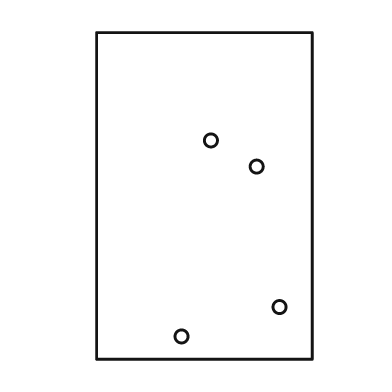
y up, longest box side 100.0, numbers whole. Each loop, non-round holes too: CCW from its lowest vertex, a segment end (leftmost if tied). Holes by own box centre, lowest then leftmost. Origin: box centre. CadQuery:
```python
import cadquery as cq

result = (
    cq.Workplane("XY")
    .moveTo(-33.0, -50.0)
    .lineTo(33.0, -50.0)
    .lineTo(33.0, 50.0)
    .lineTo(-33.0, 50.0)
    .close()
    .moveTo(-7.0, -43.0)
    .circle(2.0)
    .moveTo(23.0, -34.0)
    .circle(2.0)
    .moveTo(16.0, 9.0)
    .circle(2.0)
    .moveTo(2.0, 17.0)
    .circle(2.0)
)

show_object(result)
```